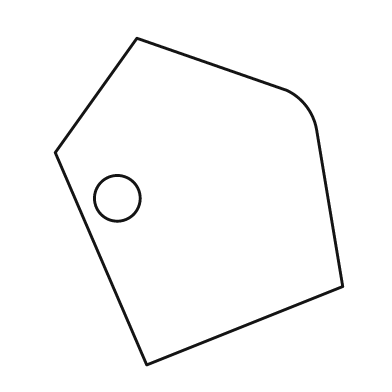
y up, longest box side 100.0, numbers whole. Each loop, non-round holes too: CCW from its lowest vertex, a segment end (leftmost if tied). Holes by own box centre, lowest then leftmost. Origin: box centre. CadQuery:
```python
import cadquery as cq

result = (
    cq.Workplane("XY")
    .moveTo(-16.0, -50.0)
    .lineTo(44.0, -26.0)
    .lineTo(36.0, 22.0)
    .threePointArc((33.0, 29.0), (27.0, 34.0))
    .lineTo(-19.0, 50.0)
    .lineTo(-44.0, 15.0)
    .close()
    .moveTo(-25.0, 1.0)
    .circle(7.0)
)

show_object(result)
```